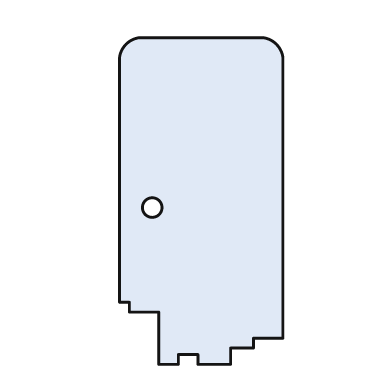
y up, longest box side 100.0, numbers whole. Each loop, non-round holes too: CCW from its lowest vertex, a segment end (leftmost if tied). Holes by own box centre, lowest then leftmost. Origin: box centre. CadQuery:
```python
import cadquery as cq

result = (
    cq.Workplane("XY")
    .moveTo(-13.0, -50.0)
    .lineTo(-7.0, -50.0)
    .lineTo(-7.0, -47.0)
    .lineTo(-1.0, -47.0)
    .lineTo(-1.0, -50.0)
    .lineTo(9.0, -50.0)
    .lineTo(9.0, -45.0)
    .lineTo(16.0, -45.0)
    .lineTo(16.0, -42.0)
    .lineTo(25.0, -42.0)
    .lineTo(25.0, 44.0)
    .threePointArc((23.0, 48.0), (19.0, 50.0))
    .lineTo(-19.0, 50.0)
    .threePointArc((-23.0, 48.0), (-25.0, 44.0))
    .lineTo(-25.0, -31.0)
    .lineTo(-22.0, -31.0)
    .lineTo(-22.0, -34.0)
    .lineTo(-13.0, -34.0)
    .close()
    .moveTo(-15.0, -2.0)
    .circle(3.0)
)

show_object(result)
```